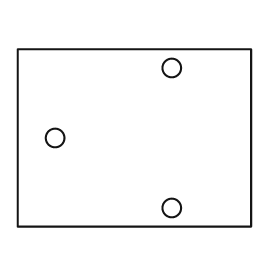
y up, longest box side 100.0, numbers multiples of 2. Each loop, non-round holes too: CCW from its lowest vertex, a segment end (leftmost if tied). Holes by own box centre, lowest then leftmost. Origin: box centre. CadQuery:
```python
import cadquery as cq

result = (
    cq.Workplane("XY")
    .moveTo(-50.0, -38.0)
    .lineTo(50.0, -38.0)
    .lineTo(50.0, 38.0)
    .lineTo(-50.0, 38.0)
    .close()
    .moveTo(16.0, -30.0)
    .circle(4.0)
    .moveTo(-34.0, 0.0)
    .circle(4.0)
    .moveTo(16.0, 30.0)
    .circle(4.0)
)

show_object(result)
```